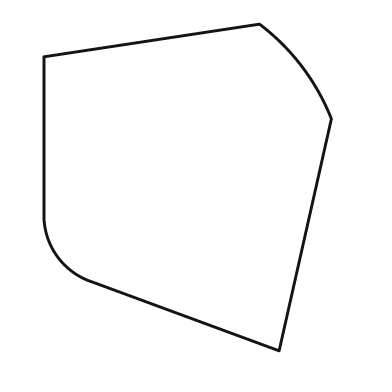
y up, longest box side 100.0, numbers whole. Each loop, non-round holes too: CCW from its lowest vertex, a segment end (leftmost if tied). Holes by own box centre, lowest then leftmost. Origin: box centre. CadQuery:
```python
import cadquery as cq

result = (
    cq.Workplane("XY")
    .moveTo(28.0, -50.0)
    .lineTo(44.0, 21.0)
    .threePointArc((35.0, 37.0), (22.0, 50.0))
    .lineTo(-44.0, 40.0)
    .lineTo(-44.0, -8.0)
    .threePointArc((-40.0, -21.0), (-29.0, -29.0))
    .close()
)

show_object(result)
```